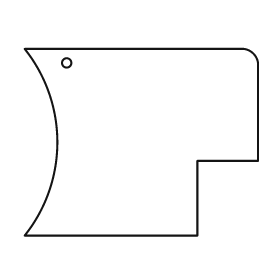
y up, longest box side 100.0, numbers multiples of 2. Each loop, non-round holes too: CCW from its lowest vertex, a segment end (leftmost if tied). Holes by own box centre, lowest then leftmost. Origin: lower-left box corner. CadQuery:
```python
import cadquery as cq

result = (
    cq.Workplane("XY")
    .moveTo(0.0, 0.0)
    .lineTo(74.0, 0.0)
    .lineTo(74.0, 32.0)
    .lineTo(100.0, 32.0)
    .lineTo(100.0, 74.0)
    .threePointArc((98.0, 78.0), (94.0, 80.0))
    .lineTo(0.0, 80.0)
    .threePointArc((14.0, 40.0), (0.0, 0.0))
    .close()
    .moveTo(18.0, 74.0)
    .circle(2.0)
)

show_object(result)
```